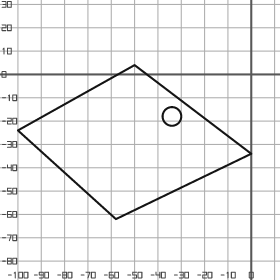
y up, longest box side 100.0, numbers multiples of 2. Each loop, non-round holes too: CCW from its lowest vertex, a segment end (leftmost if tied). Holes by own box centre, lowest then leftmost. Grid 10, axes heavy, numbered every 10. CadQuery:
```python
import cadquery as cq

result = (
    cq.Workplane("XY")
    .moveTo(-58.0, -62.0)
    .lineTo(0.0, -34.0)
    .lineTo(-50.0, 4.0)
    .lineTo(-100.0, -24.0)
    .close()
    .moveTo(-34.0, -18.0)
    .circle(4.0)
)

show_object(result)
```